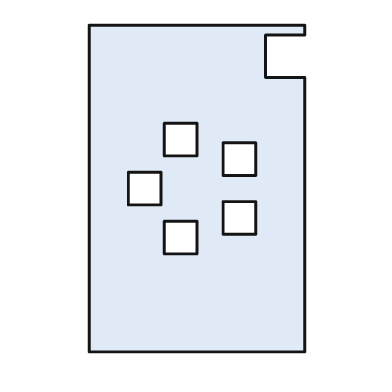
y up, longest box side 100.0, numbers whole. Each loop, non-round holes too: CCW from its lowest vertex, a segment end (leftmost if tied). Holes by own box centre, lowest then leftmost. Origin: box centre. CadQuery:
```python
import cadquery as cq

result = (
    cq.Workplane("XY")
    .moveTo(-33.0, -50.0)
    .lineTo(33.0, -50.0)
    .lineTo(33.0, 34.0)
    .lineTo(21.0, 34.0)
    .lineTo(21.0, 47.0)
    .lineTo(33.0, 47.0)
    .lineTo(33.0, 50.0)
    .lineTo(-33.0, 50.0)
    .close()
    .moveTo(-10.0, -20.0)
    .lineTo(0.0, -20.0)
    .lineTo(0.0, -10.0)
    .lineTo(-10.0, -10.0)
    .close()
    .moveTo(8.0, -14.0)
    .lineTo(18.0, -14.0)
    .lineTo(18.0, -4.0)
    .lineTo(8.0, -4.0)
    .close()
    .moveTo(-21.0, -5.0)
    .lineTo(-11.0, -5.0)
    .lineTo(-11.0, 5.0)
    .lineTo(-21.0, 5.0)
    .close()
    .moveTo(8.0, 4.0)
    .lineTo(18.0, 4.0)
    .lineTo(18.0, 14.0)
    .lineTo(8.0, 14.0)
    .close()
    .moveTo(-10.0, 10.0)
    .lineTo(0.0, 10.0)
    .lineTo(0.0, 20.0)
    .lineTo(-10.0, 20.0)
    .close()
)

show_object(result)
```